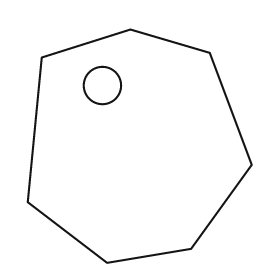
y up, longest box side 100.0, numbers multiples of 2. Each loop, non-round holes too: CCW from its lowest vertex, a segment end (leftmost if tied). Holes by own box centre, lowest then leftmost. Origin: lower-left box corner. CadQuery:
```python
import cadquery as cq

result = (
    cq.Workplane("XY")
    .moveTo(34.0, 0.0)
    .lineTo(70.0, 6.0)
    .lineTo(96.0, 42.0)
    .lineTo(78.0, 90.0)
    .lineTo(44.0, 100.0)
    .lineTo(6.0, 88.0)
    .lineTo(0.0, 26.0)
    .close()
    .moveTo(32.0, 76.0)
    .circle(8.0)
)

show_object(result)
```